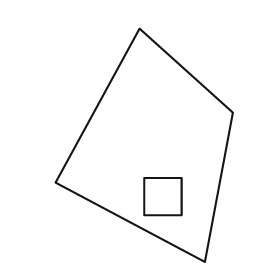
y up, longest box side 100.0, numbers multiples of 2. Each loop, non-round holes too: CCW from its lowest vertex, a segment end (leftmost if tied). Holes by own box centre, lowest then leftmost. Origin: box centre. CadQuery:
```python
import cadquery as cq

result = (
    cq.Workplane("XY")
    .moveTo(26.0, -50.0)
    .lineTo(38.0, 14.0)
    .lineTo(-2.0, 50.0)
    .lineTo(-38.0, -16.0)
    .close()
    .moveTo(0.0, -30.0)
    .lineTo(16.0, -30.0)
    .lineTo(16.0, -14.0)
    .lineTo(0.0, -14.0)
    .close()
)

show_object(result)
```